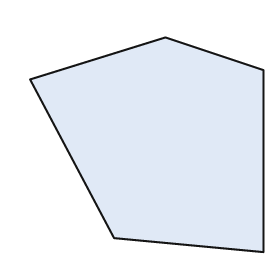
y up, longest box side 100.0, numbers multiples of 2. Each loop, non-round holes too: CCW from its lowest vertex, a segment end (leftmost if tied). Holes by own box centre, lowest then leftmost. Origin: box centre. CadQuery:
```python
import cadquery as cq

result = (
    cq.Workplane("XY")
    .moveTo(50.0, -46.0)
    .lineTo(50.0, 32.0)
    .lineTo(8.0, 46.0)
    .lineTo(-50.0, 28.0)
    .lineTo(-14.0, -40.0)
    .close()
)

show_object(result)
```